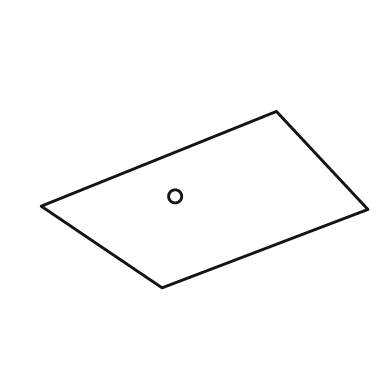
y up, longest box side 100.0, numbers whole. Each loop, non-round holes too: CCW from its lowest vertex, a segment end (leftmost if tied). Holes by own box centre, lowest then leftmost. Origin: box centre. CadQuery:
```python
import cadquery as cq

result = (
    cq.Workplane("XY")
    .moveTo(-13.0, -27.0)
    .lineTo(50.0, -3.0)
    .lineTo(22.0, 27.0)
    .lineTo(-50.0, -2.0)
    .close()
    .moveTo(-9.0, 1.0)
    .circle(2.0)
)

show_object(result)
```